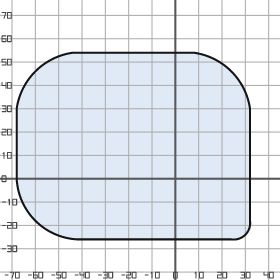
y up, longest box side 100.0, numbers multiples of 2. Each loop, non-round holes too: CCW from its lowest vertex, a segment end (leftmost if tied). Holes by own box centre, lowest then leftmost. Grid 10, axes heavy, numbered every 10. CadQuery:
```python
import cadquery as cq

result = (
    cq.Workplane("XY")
    .moveTo(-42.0, -26.0)
    .lineTo(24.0, -26.0)
    .threePointArc((30.0, -24.0), (32.0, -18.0))
    .lineTo(32.0, 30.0)
    .threePointArc((24.0, 46.0), (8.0, 54.0))
    .lineTo(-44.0, 54.0)
    .threePointArc((-60.0, 46.0), (-68.0, 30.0))
    .lineTo(-68.0, 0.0)
    .threePointArc((-60.0, -18.0), (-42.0, -26.0))
    .close()
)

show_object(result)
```